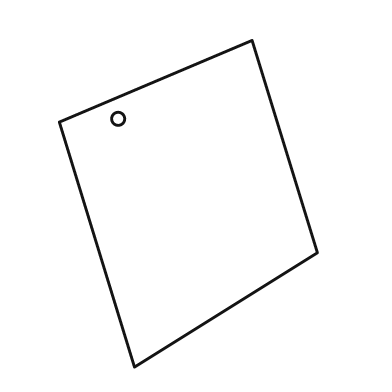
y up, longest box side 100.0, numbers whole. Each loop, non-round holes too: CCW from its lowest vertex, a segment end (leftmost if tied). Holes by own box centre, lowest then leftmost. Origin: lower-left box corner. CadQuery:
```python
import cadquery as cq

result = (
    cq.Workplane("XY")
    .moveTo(23.0, 0.0)
    .lineTo(79.0, 35.0)
    .lineTo(59.0, 100.0)
    .lineTo(0.0, 75.0)
    .close()
    .moveTo(18.0, 76.0)
    .circle(2.0)
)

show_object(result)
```